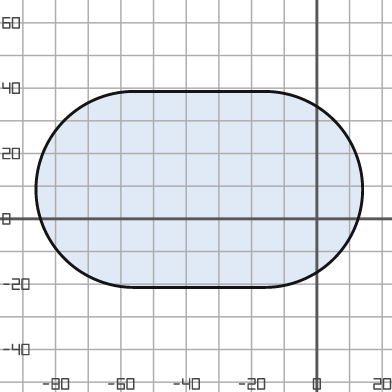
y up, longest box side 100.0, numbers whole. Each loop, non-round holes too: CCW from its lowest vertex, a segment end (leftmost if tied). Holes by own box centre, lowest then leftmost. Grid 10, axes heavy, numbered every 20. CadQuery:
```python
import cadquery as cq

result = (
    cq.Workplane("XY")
    .moveTo(-56.0, -21.0)
    .lineTo(-16.0, -21.0)
    .threePointArc((14.0, 9.0), (-16.0, 39.0))
    .lineTo(-56.0, 39.0)
    .threePointArc((-86.0, 9.0), (-56.0, -21.0))
    .close()
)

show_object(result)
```